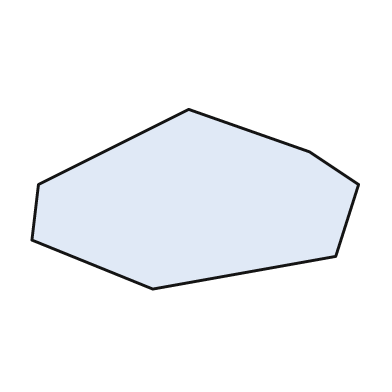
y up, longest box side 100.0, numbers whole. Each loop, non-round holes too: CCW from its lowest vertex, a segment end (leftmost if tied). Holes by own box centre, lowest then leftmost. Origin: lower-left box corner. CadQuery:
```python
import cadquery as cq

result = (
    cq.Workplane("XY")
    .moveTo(37.0, 0.0)
    .lineTo(93.0, 10.0)
    .lineTo(100.0, 32.0)
    .lineTo(85.0, 42.0)
    .lineTo(48.0, 55.0)
    .lineTo(2.0, 32.0)
    .lineTo(0.0, 15.0)
    .close()
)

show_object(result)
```